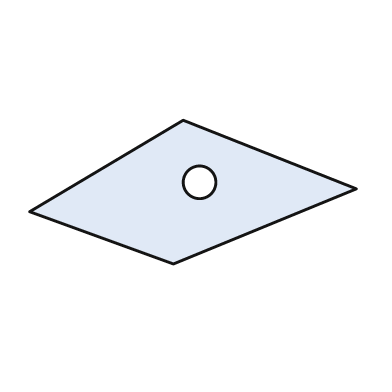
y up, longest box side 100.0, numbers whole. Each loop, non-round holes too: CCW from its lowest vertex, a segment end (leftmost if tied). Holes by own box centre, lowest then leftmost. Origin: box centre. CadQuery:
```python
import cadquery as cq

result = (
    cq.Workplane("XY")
    .moveTo(-6.0, -22.0)
    .lineTo(50.0, 1.0)
    .lineTo(-3.0, 22.0)
    .lineTo(-50.0, -6.0)
    .close()
    .moveTo(2.0, 3.0)
    .circle(5.0)
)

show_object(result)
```